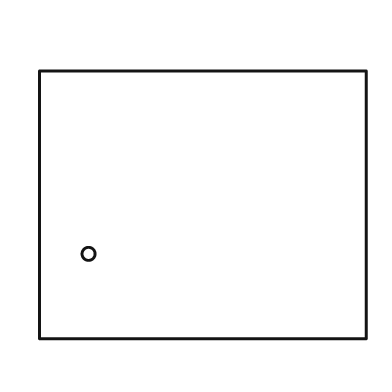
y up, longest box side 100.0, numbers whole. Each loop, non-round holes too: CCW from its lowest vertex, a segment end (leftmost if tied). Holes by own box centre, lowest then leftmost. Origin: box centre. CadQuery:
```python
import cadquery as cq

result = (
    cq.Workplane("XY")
    .moveTo(-50.0, -41.0)
    .lineTo(50.0, -41.0)
    .lineTo(50.0, 41.0)
    .lineTo(-50.0, 41.0)
    .close()
    .moveTo(-35.0, -15.0)
    .circle(2.0)
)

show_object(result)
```